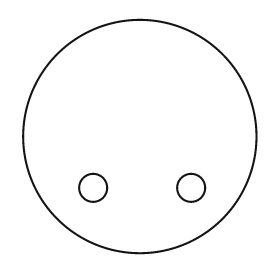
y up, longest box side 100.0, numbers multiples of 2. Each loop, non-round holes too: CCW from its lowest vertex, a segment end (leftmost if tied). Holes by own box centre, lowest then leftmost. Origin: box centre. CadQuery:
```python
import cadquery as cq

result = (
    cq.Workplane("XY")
    .moveTo(0.0, 0.0)
    .circle(50.0)
    .moveTo(-20.0, -22.0)
    .circle(6.0)
    .moveTo(22.0, -22.0)
    .circle(6.0)
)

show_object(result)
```